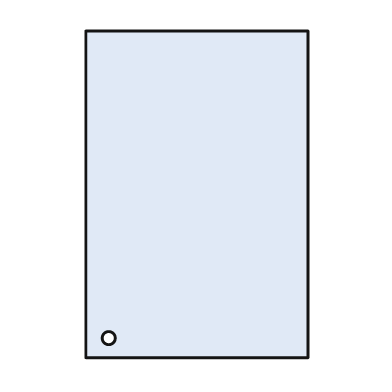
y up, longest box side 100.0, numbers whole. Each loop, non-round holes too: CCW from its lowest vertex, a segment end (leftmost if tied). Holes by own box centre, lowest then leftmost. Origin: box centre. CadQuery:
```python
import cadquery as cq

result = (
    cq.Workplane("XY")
    .moveTo(-34.0, -50.0)
    .lineTo(34.0, -50.0)
    .lineTo(34.0, 50.0)
    .lineTo(-34.0, 50.0)
    .close()
    .moveTo(-27.0, -44.0)
    .circle(2.0)
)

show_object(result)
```